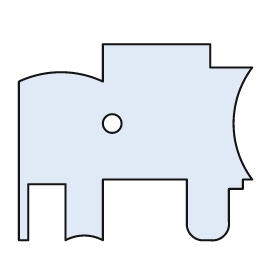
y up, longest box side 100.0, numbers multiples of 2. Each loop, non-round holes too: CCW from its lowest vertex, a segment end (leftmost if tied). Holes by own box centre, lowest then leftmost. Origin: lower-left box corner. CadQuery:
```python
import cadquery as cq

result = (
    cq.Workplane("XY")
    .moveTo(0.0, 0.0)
    .lineTo(4.0, 0.0)
    .lineTo(4.0, 24.0)
    .lineTo(20.0, 24.0)
    .lineTo(20.0, 0.0)
    .threePointArc((28.0, 2.0), (36.0, 0.0))
    .lineTo(36.0, 26.0)
    .lineTo(72.0, 26.0)
    .lineTo(72.0, 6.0)
    .threePointArc((74.0, 2.0), (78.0, 0.0))
    .lineTo(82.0, 0.0)
    .threePointArc((88.0, 2.0), (90.0, 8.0))
    .lineTo(90.0, 22.0)
    .lineTo(96.0, 22.0)
    .lineTo(96.0, 26.0)
    .lineTo(100.0, 26.0)
    .threePointArc((92.0, 50.0), (100.0, 74.0))
    .lineTo(82.0, 74.0)
    .lineTo(82.0, 84.0)
    .lineTo(36.0, 84.0)
    .lineTo(36.0, 68.0)
    .threePointArc((18.0, 72.0), (0.0, 68.0))
    .close()
    .moveTo(40.0, 50.0)
    .circle(4.0)
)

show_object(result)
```